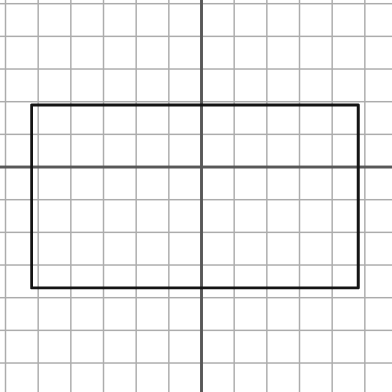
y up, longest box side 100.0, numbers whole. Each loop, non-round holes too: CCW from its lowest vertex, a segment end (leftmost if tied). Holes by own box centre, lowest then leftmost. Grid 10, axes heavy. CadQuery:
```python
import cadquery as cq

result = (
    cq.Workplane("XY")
    .moveTo(-52.0, -37.0)
    .lineTo(48.0, -37.0)
    .lineTo(48.0, 19.0)
    .lineTo(-52.0, 19.0)
    .close()
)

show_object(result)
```